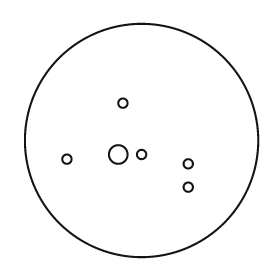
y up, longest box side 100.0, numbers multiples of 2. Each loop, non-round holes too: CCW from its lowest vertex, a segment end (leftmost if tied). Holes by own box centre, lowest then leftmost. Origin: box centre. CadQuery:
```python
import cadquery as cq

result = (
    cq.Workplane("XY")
    .moveTo(0.0, 0.0)
    .circle(50.0)
    .moveTo(20.0, -20.0)
    .circle(2.0)
    .moveTo(20.0, -10.0)
    .circle(2.0)
    .moveTo(-32.0, -8.0)
    .circle(2.0)
    .moveTo(-10.0, -6.0)
    .circle(4.0)
    .moveTo(0.0, -6.0)
    .circle(2.0)
    .moveTo(-8.0, 16.0)
    .circle(2.0)
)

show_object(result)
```